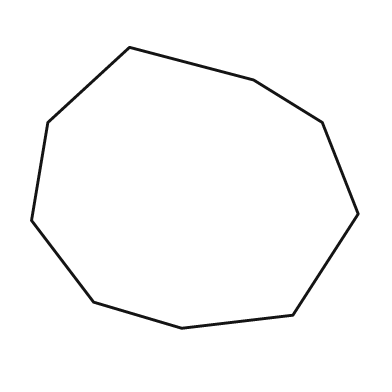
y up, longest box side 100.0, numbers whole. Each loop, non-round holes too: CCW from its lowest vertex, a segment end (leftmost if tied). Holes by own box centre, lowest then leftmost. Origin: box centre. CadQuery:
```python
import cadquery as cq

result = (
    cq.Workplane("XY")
    .moveTo(-4.0, -43.0)
    .lineTo(30.0, -39.0)
    .lineTo(50.0, -8.0)
    .lineTo(39.0, 20.0)
    .lineTo(18.0, 33.0)
    .lineTo(-20.0, 43.0)
    .lineTo(-45.0, 20.0)
    .lineTo(-50.0, -10.0)
    .lineTo(-31.0, -35.0)
    .close()
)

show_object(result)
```